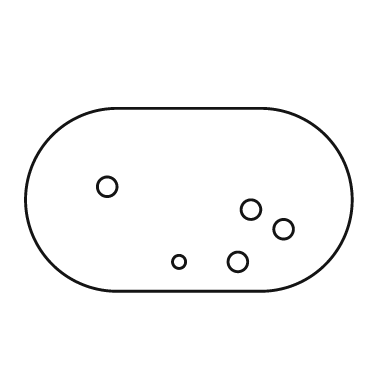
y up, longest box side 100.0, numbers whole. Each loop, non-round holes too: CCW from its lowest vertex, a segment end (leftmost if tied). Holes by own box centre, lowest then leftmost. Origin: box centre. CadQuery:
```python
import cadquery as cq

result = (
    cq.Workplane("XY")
    .moveTo(-22.0, -28.0)
    .lineTo(22.0, -28.0)
    .threePointArc((50.0, 0.0), (22.0, 28.0))
    .lineTo(-22.0, 28.0)
    .threePointArc((-50.0, 0.0), (-22.0, -28.0))
    .close()
    .moveTo(-3.0, -19.0)
    .circle(2.0)
    .moveTo(15.0, -19.0)
    .circle(3.0)
    .moveTo(29.0, -9.0)
    .circle(3.0)
    .moveTo(19.0, -3.0)
    .circle(3.0)
    .moveTo(-25.0, 4.0)
    .circle(3.0)
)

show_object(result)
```